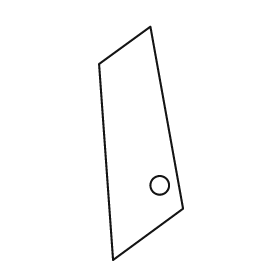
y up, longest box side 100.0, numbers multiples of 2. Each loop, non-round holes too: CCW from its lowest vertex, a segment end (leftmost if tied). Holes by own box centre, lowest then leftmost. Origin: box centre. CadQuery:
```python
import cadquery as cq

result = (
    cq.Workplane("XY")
    .moveTo(-12.0, -50.0)
    .lineTo(18.0, -28.0)
    .lineTo(4.0, 50.0)
    .lineTo(-18.0, 34.0)
    .close()
    .moveTo(8.0, -18.0)
    .circle(4.0)
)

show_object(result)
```